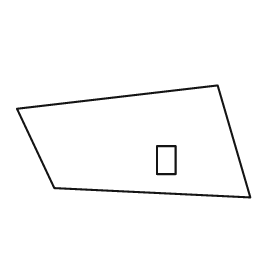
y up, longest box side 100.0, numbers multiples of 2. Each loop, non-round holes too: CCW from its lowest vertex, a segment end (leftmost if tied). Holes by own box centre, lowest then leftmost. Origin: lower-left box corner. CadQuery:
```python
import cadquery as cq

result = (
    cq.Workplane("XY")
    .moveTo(100.0, 0.0)
    .lineTo(86.0, 48.0)
    .lineTo(0.0, 38.0)
    .lineTo(16.0, 4.0)
    .close()
    .moveTo(60.0, 10.0)
    .lineTo(68.0, 10.0)
    .lineTo(68.0, 22.0)
    .lineTo(60.0, 22.0)
    .close()
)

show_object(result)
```